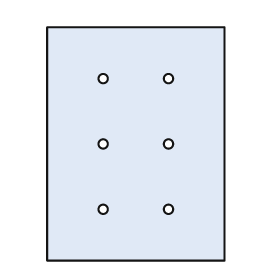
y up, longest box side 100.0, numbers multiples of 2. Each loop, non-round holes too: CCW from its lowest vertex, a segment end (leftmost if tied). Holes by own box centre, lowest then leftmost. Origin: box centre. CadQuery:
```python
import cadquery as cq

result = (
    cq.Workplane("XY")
    .moveTo(-38.0, -50.0)
    .lineTo(38.0, -50.0)
    .lineTo(38.0, 50.0)
    .lineTo(-38.0, 50.0)
    .close()
    .moveTo(-14.0, -28.0)
    .circle(2.0)
    .moveTo(14.0, -28.0)
    .circle(2.0)
    .moveTo(-14.0, 0.0)
    .circle(2.0)
    .moveTo(14.0, 0.0)
    .circle(2.0)
    .moveTo(-14.0, 28.0)
    .circle(2.0)
    .moveTo(14.0, 28.0)
    .circle(2.0)
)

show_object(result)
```